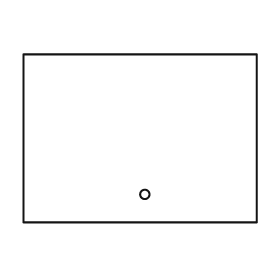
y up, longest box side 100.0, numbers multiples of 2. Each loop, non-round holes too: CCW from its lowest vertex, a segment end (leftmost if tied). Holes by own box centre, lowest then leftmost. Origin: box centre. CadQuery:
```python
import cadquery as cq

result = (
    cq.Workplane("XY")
    .moveTo(-50.0, -36.0)
    .lineTo(50.0, -36.0)
    .lineTo(50.0, 36.0)
    .lineTo(-50.0, 36.0)
    .close()
    .moveTo(2.0, -24.0)
    .circle(2.0)
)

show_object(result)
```